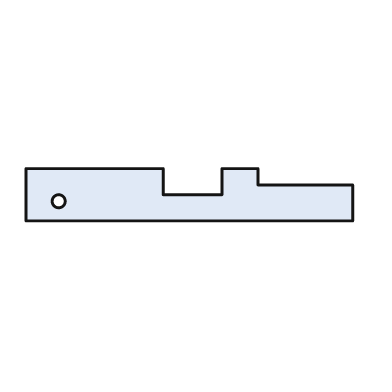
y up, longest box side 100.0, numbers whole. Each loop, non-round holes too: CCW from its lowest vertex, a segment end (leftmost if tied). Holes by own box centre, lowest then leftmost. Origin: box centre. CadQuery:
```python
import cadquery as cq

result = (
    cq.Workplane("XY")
    .moveTo(-50.0, -8.0)
    .lineTo(50.0, -8.0)
    .lineTo(50.0, 3.0)
    .lineTo(21.0, 3.0)
    .lineTo(21.0, 8.0)
    .lineTo(10.0, 8.0)
    .lineTo(10.0, 0.0)
    .lineTo(-8.0, 0.0)
    .lineTo(-8.0, 8.0)
    .lineTo(-50.0, 8.0)
    .close()
    .moveTo(-40.0, -2.0)
    .circle(2.0)
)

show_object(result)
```